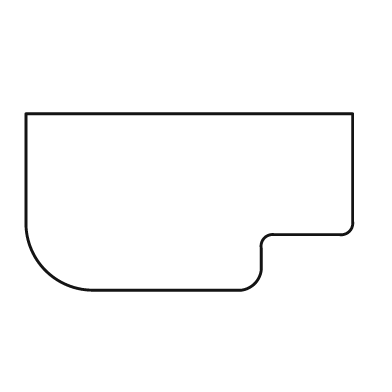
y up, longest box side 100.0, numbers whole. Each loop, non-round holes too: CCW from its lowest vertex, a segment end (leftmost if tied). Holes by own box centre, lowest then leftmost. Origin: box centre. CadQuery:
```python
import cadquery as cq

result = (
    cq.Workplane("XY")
    .moveTo(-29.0, -27.0)
    .lineTo(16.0, -27.0)
    .threePointArc((20.0, -25.0), (22.0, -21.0))
    .lineTo(22.0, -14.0)
    .threePointArc((23.0, -11.0), (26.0, -10.0))
    .lineTo(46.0, -10.0)
    .threePointArc((49.0, -9.0), (50.0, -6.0))
    .lineTo(50.0, 27.0)
    .lineTo(-50.0, 27.0)
    .lineTo(-50.0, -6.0)
    .threePointArc((-44.0, -21.0), (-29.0, -27.0))
    .close()
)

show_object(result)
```